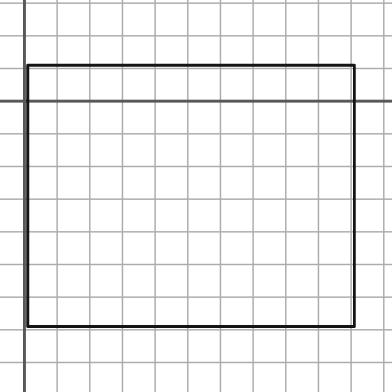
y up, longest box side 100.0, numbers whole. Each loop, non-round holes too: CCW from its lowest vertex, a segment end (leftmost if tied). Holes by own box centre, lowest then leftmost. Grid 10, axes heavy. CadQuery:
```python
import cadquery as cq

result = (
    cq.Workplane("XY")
    .moveTo(1.0, -69.0)
    .lineTo(101.0, -69.0)
    .lineTo(101.0, 11.0)
    .lineTo(1.0, 11.0)
    .close()
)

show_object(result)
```